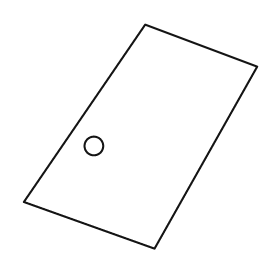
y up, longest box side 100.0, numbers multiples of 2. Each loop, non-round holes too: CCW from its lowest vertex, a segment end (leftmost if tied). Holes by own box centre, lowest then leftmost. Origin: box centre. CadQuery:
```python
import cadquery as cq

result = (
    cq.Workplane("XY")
    .moveTo(6.0, -48.0)
    .lineTo(50.0, 30.0)
    .lineTo(2.0, 48.0)
    .lineTo(-50.0, -28.0)
    .close()
    .moveTo(-20.0, -4.0)
    .circle(4.0)
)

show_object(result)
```